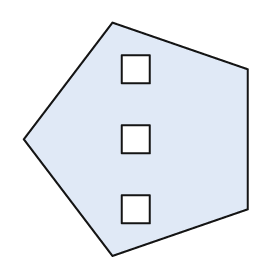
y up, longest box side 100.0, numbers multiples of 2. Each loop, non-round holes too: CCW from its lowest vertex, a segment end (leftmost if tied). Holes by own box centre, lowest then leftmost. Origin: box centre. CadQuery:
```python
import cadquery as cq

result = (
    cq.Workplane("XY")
    .moveTo(-10.0, -50.0)
    .lineTo(48.0, -30.0)
    .lineTo(48.0, 30.0)
    .lineTo(-10.0, 50.0)
    .lineTo(-48.0, 0.0)
    .close()
    .moveTo(-6.0, -36.0)
    .lineTo(6.0, -36.0)
    .lineTo(6.0, -24.0)
    .lineTo(-6.0, -24.0)
    .close()
    .moveTo(-6.0, -6.0)
    .lineTo(6.0, -6.0)
    .lineTo(6.0, 6.0)
    .lineTo(-6.0, 6.0)
    .close()
    .moveTo(-6.0, 24.0)
    .lineTo(6.0, 24.0)
    .lineTo(6.0, 36.0)
    .lineTo(-6.0, 36.0)
    .close()
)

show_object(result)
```